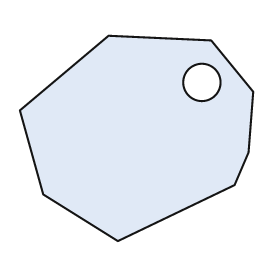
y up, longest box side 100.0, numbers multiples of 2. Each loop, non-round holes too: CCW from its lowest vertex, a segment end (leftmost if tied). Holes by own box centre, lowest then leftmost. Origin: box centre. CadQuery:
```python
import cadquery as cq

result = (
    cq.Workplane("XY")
    .moveTo(-8.0, -44.0)
    .lineTo(42.0, -20.0)
    .lineTo(48.0, -6.0)
    .lineTo(50.0, 20.0)
    .lineTo(32.0, 42.0)
    .lineTo(-12.0, 44.0)
    .lineTo(-50.0, 12.0)
    .lineTo(-40.0, -24.0)
    .close()
    .moveTo(28.0, 24.0)
    .circle(8.0)
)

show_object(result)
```